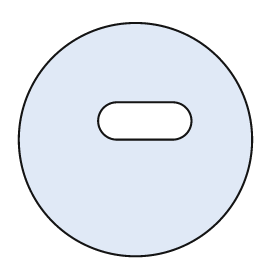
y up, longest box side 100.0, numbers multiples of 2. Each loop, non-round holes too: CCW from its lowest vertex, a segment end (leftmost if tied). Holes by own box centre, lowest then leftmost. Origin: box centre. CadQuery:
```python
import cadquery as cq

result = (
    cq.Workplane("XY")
    .moveTo(0.0, 0.0)
    .circle(50.0)
    .moveTo(-8.0, 0.0)
    .lineTo(16.0, 0.0)
    .threePointArc((24.0, 8.0), (16.0, 16.0))
    .lineTo(-8.0, 16.0)
    .threePointArc((-16.0, 8.0), (-8.0, 0.0))
    .close()
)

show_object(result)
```